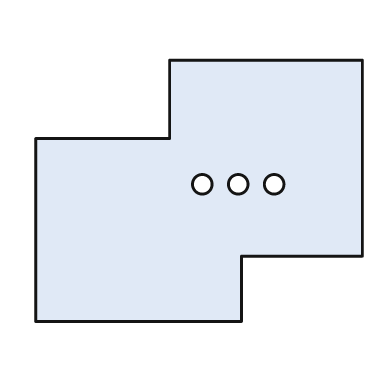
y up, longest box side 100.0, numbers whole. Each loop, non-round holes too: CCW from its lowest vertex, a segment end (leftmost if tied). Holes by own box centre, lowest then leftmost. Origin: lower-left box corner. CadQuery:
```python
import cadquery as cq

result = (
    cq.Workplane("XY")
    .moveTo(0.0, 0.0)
    .lineTo(63.0, 0.0)
    .lineTo(63.0, 20.0)
    .lineTo(100.0, 20.0)
    .lineTo(100.0, 80.0)
    .lineTo(41.0, 80.0)
    .lineTo(41.0, 56.0)
    .lineTo(0.0, 56.0)
    .close()
    .moveTo(51.0, 42.0)
    .circle(3.0)
    .moveTo(62.0, 42.0)
    .circle(3.0)
    .moveTo(73.0, 42.0)
    .circle(3.0)
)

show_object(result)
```